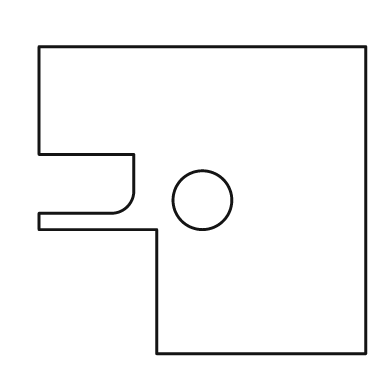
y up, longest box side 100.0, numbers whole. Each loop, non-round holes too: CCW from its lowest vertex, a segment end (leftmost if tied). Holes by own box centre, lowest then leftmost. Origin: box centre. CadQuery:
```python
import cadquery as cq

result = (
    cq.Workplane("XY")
    .moveTo(-14.0, -47.0)
    .lineTo(50.0, -47.0)
    .lineTo(50.0, 47.0)
    .lineTo(-50.0, 47.0)
    .lineTo(-50.0, 14.0)
    .lineTo(-21.0, 14.0)
    .lineTo(-21.0, 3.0)
    .threePointArc((-23.0, -2.0), (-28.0, -4.0))
    .lineTo(-50.0, -4.0)
    .lineTo(-50.0, -9.0)
    .lineTo(-14.0, -9.0)
    .close()
    .moveTo(0.0, 0.0)
    .circle(9.0)
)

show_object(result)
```